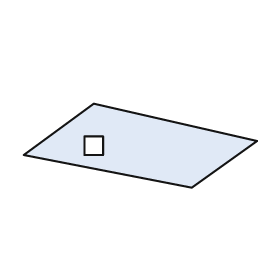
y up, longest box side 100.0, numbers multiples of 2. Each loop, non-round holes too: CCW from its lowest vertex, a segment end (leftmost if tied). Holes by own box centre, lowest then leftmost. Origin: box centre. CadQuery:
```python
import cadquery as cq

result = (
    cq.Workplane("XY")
    .moveTo(22.0, -18.0)
    .lineTo(50.0, 2.0)
    .lineTo(-20.0, 18.0)
    .lineTo(-50.0, -4.0)
    .close()
    .moveTo(-24.0, -4.0)
    .lineTo(-16.0, -4.0)
    .lineTo(-16.0, 4.0)
    .lineTo(-24.0, 4.0)
    .close()
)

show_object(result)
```